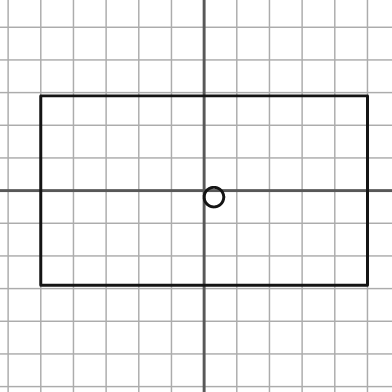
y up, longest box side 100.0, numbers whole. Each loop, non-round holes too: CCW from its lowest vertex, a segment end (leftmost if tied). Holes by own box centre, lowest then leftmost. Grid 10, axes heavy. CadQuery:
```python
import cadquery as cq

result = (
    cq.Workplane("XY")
    .moveTo(-50.0, -29.0)
    .lineTo(50.0, -29.0)
    .lineTo(50.0, 29.0)
    .lineTo(-50.0, 29.0)
    .close()
    .moveTo(3.0, -2.0)
    .circle(3.0)
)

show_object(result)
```